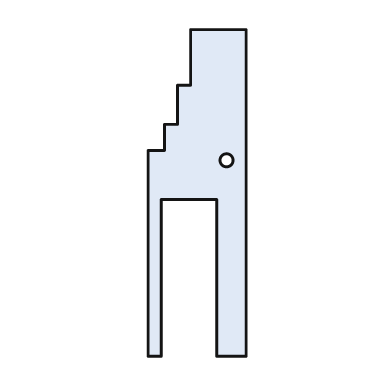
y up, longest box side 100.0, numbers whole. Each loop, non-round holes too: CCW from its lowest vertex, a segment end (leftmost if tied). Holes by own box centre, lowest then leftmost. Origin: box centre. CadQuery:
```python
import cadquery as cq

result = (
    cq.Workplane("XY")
    .moveTo(-15.0, -50.0)
    .lineTo(-11.0, -50.0)
    .lineTo(-11.0, -2.0)
    .lineTo(6.0, -2.0)
    .lineTo(6.0, -50.0)
    .lineTo(15.0, -50.0)
    .lineTo(15.0, 50.0)
    .lineTo(-2.0, 50.0)
    .lineTo(-2.0, 33.0)
    .lineTo(-6.0, 33.0)
    .lineTo(-6.0, 21.0)
    .lineTo(-10.0, 21.0)
    .lineTo(-10.0, 13.0)
    .lineTo(-15.0, 13.0)
    .close()
    .moveTo(9.0, 10.0)
    .circle(2.0)
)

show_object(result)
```